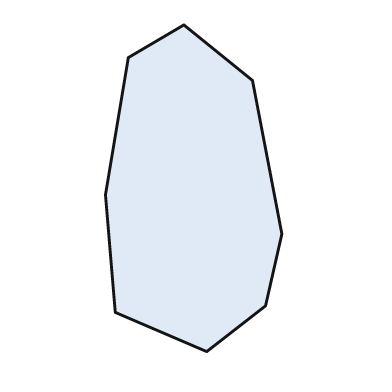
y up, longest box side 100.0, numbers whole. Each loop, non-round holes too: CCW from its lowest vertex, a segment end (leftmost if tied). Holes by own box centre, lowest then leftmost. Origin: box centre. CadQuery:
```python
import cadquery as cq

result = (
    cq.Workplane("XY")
    .moveTo(4.0, -50.0)
    .lineTo(22.0, -36.0)
    .lineTo(27.0, -14.0)
    .lineTo(18.0, 33.0)
    .lineTo(-3.0, 50.0)
    .lineTo(-20.0, 40.0)
    .lineTo(-27.0, -2.0)
    .lineTo(-24.0, -38.0)
    .close()
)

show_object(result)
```